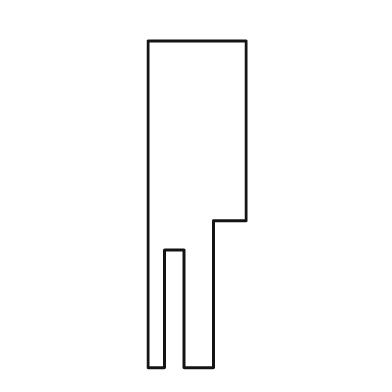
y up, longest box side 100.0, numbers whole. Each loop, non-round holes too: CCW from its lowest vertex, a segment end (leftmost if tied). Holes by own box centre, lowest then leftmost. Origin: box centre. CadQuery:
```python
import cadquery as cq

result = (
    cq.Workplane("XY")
    .moveTo(-15.0, -50.0)
    .lineTo(-10.0, -50.0)
    .lineTo(-10.0, -14.0)
    .lineTo(-4.0, -14.0)
    .lineTo(-4.0, -50.0)
    .lineTo(5.0, -50.0)
    .lineTo(5.0, -5.0)
    .lineTo(15.0, -5.0)
    .lineTo(15.0, 50.0)
    .lineTo(-15.0, 50.0)
    .close()
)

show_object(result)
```